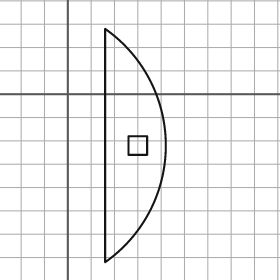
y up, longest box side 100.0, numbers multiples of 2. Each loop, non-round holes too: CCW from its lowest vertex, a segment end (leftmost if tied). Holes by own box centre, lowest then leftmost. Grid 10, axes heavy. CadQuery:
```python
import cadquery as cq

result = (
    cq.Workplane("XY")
    .moveTo(16.0, -72.0)
    .threePointArc((42.0, -22.0), (16.0, 28.0))
    .close()
    .moveTo(26.0, -26.0)
    .lineTo(34.0, -26.0)
    .lineTo(34.0, -18.0)
    .lineTo(26.0, -18.0)
    .close()
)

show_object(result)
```